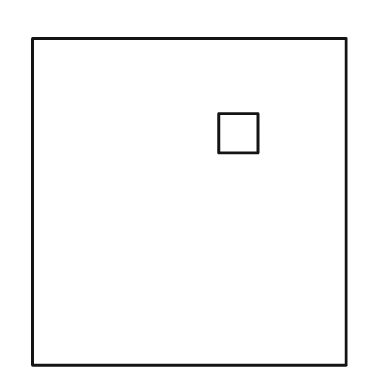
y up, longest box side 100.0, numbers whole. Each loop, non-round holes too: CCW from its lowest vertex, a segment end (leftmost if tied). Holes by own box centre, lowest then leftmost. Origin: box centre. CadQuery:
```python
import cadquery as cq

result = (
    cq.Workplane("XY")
    .moveTo(-48.0, -50.0)
    .lineTo(48.0, -50.0)
    .lineTo(48.0, 50.0)
    .lineTo(-48.0, 50.0)
    .close()
    .moveTo(9.0, 15.0)
    .lineTo(21.0, 15.0)
    .lineTo(21.0, 27.0)
    .lineTo(9.0, 27.0)
    .close()
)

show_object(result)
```